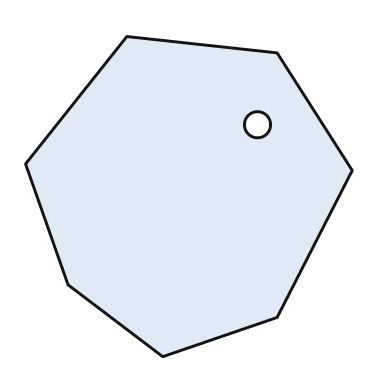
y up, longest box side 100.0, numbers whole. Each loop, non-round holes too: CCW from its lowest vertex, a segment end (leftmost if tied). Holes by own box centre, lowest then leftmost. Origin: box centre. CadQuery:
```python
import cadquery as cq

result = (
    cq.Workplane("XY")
    .moveTo(-8.0, -49.0)
    .lineTo(27.0, -37.0)
    .lineTo(50.0, 8.0)
    .lineTo(27.0, 44.0)
    .lineTo(-19.0, 49.0)
    .lineTo(-50.0, 10.0)
    .lineTo(-37.0, -27.0)
    .close()
    .moveTo(21.0, 22.0)
    .circle(4.0)
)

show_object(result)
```